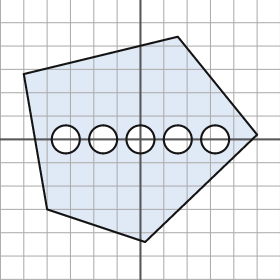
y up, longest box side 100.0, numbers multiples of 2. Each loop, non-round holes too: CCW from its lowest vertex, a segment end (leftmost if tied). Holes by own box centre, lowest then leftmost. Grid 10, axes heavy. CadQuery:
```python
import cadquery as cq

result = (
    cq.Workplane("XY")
    .moveTo(2.0, -44.0)
    .lineTo(50.0, 2.0)
    .lineTo(16.0, 44.0)
    .lineTo(-50.0, 28.0)
    .lineTo(-40.0, -30.0)
    .close()
    .moveTo(-32.0, 0.0)
    .circle(6.0)
    .moveTo(-16.0, 0.0)
    .circle(6.0)
    .moveTo(0.0, 0.0)
    .circle(6.0)
    .moveTo(16.0, 0.0)
    .circle(6.0)
    .moveTo(32.0, 0.0)
    .circle(6.0)
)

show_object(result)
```